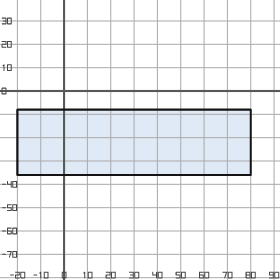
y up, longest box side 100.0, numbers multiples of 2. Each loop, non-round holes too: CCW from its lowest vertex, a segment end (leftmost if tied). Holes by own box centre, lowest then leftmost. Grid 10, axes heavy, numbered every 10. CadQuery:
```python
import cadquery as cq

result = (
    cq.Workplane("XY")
    .moveTo(-20.0, -36.0)
    .lineTo(80.0, -36.0)
    .lineTo(80.0, -8.0)
    .lineTo(-20.0, -8.0)
    .close()
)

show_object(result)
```